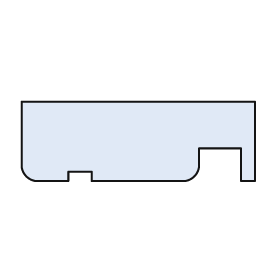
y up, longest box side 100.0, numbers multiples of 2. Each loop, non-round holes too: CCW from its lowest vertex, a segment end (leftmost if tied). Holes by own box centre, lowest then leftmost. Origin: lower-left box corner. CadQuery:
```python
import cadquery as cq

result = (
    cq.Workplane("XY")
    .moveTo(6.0, 0.0)
    .lineTo(20.0, 0.0)
    .lineTo(20.0, 4.0)
    .lineTo(30.0, 4.0)
    .lineTo(30.0, 0.0)
    .lineTo(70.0, 0.0)
    .threePointArc((74.0, 2.0), (76.0, 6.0))
    .lineTo(76.0, 14.0)
    .lineTo(94.0, 14.0)
    .lineTo(94.0, 0.0)
    .lineTo(100.0, 0.0)
    .lineTo(100.0, 34.0)
    .lineTo(0.0, 34.0)
    .lineTo(0.0, 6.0)
    .threePointArc((2.0, 2.0), (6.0, 0.0))
    .close()
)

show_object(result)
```